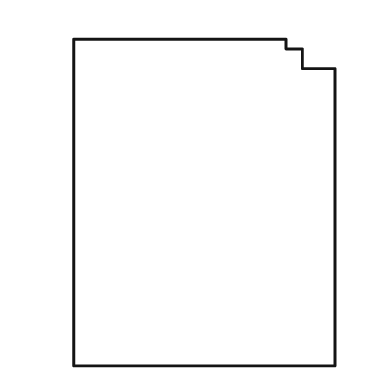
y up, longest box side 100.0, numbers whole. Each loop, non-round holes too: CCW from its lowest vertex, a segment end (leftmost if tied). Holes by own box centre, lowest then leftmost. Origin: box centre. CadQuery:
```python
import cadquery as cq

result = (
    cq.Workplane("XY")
    .moveTo(-40.0, -50.0)
    .lineTo(40.0, -50.0)
    .lineTo(40.0, 41.0)
    .lineTo(30.0, 41.0)
    .lineTo(30.0, 47.0)
    .lineTo(25.0, 47.0)
    .lineTo(25.0, 50.0)
    .lineTo(-40.0, 50.0)
    .close()
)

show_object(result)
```